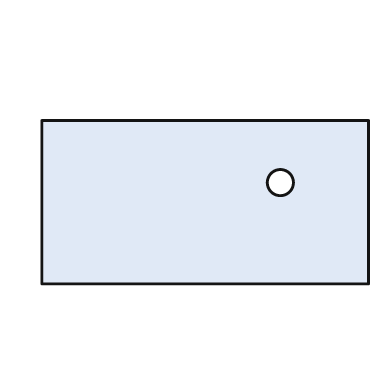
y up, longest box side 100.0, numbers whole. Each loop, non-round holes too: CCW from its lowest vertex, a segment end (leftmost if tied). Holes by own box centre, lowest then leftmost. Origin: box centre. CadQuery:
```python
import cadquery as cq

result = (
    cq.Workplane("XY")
    .moveTo(-50.0, -25.0)
    .lineTo(50.0, -25.0)
    .lineTo(50.0, 25.0)
    .lineTo(-50.0, 25.0)
    .close()
    .moveTo(23.0, 6.0)
    .circle(4.0)
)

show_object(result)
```